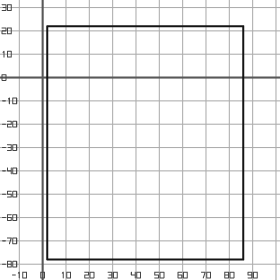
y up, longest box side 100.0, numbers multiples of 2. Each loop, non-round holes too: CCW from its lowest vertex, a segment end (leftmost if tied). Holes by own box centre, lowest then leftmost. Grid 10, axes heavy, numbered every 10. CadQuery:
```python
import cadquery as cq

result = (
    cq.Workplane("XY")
    .moveTo(2.0, -78.0)
    .lineTo(86.0, -78.0)
    .lineTo(86.0, 22.0)
    .lineTo(2.0, 22.0)
    .close()
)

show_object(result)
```